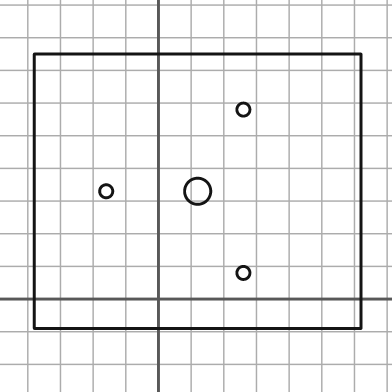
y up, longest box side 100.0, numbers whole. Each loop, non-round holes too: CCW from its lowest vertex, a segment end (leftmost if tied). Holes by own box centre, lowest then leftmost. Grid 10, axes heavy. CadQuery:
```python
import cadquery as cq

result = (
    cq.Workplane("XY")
    .moveTo(-38.0, -9.0)
    .lineTo(62.0, -9.0)
    .lineTo(62.0, 75.0)
    .lineTo(-38.0, 75.0)
    .close()
    .moveTo(26.0, 8.0)
    .circle(2.0)
    .moveTo(-16.0, 33.0)
    .circle(2.0)
    .moveTo(12.0, 33.0)
    .circle(4.0)
    .moveTo(26.0, 58.0)
    .circle(2.0)
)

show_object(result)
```